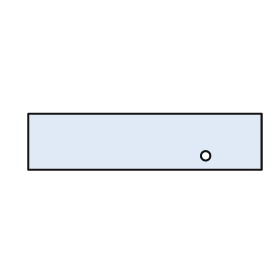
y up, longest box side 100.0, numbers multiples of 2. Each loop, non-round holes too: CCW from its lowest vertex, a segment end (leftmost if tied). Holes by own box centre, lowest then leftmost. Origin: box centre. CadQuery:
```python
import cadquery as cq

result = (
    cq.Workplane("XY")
    .moveTo(-50.0, -12.0)
    .lineTo(50.0, -12.0)
    .lineTo(50.0, 12.0)
    .lineTo(-50.0, 12.0)
    .close()
    .moveTo(26.0, -6.0)
    .circle(2.0)
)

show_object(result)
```